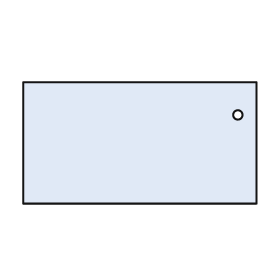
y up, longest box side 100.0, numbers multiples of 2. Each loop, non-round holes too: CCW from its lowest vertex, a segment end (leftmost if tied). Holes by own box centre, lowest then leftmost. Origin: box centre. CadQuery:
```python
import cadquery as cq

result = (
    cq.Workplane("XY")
    .moveTo(-50.0, -26.0)
    .lineTo(50.0, -26.0)
    .lineTo(50.0, 26.0)
    .lineTo(-50.0, 26.0)
    .close()
    .moveTo(42.0, 12.0)
    .circle(2.0)
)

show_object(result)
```